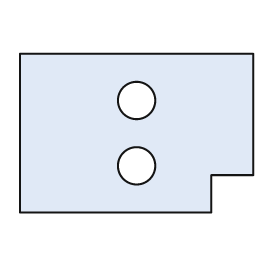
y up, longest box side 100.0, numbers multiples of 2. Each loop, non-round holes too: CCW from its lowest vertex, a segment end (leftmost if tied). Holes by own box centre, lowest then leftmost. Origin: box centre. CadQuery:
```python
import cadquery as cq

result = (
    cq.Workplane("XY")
    .moveTo(-50.0, -34.0)
    .lineTo(32.0, -34.0)
    .lineTo(32.0, -18.0)
    .lineTo(50.0, -18.0)
    .lineTo(50.0, 34.0)
    .lineTo(-50.0, 34.0)
    .close()
    .moveTo(0.0, -14.0)
    .circle(8.0)
    .moveTo(0.0, 14.0)
    .circle(8.0)
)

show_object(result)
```